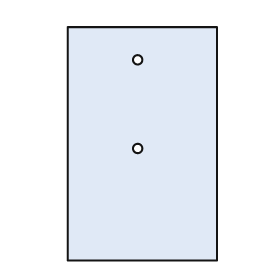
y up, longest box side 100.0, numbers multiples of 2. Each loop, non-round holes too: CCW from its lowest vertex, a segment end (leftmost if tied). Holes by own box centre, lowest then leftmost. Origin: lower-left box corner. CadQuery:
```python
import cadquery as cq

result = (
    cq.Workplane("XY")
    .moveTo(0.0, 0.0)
    .lineTo(64.0, 0.0)
    .lineTo(64.0, 100.0)
    .lineTo(0.0, 100.0)
    .close()
    .moveTo(30.0, 48.0)
    .circle(2.0)
    .moveTo(30.0, 86.0)
    .circle(2.0)
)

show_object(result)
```